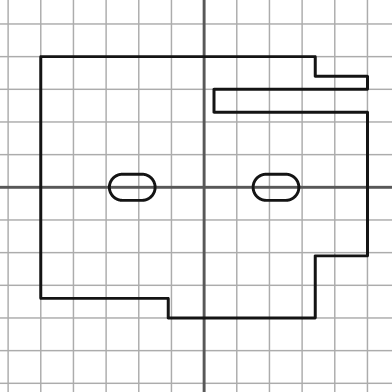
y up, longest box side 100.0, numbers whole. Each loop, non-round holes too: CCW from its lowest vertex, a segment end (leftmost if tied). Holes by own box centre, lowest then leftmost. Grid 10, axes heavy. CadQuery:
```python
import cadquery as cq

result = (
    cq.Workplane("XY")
    .moveTo(-11.0, -40.0)
    .lineTo(34.0, -40.0)
    .lineTo(34.0, -21.0)
    .lineTo(50.0, -21.0)
    .lineTo(50.0, 23.0)
    .lineTo(3.0, 23.0)
    .lineTo(3.0, 30.0)
    .lineTo(50.0, 30.0)
    .lineTo(50.0, 34.0)
    .lineTo(34.0, 34.0)
    .lineTo(34.0, 40.0)
    .lineTo(-50.0, 40.0)
    .lineTo(-50.0, -34.0)
    .lineTo(-11.0, -34.0)
    .close()
    .moveTo(-25.0, -4.0)
    .lineTo(-19.0, -4.0)
    .threePointArc((-15.0, 0.0), (-19.0, 4.0))
    .lineTo(-25.0, 4.0)
    .threePointArc((-29.0, 0.0), (-25.0, -4.0))
    .close()
    .moveTo(19.0, -4.0)
    .lineTo(25.0, -4.0)
    .threePointArc((29.0, 0.0), (25.0, 4.0))
    .lineTo(19.0, 4.0)
    .threePointArc((15.0, 0.0), (19.0, -4.0))
    .close()
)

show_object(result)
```